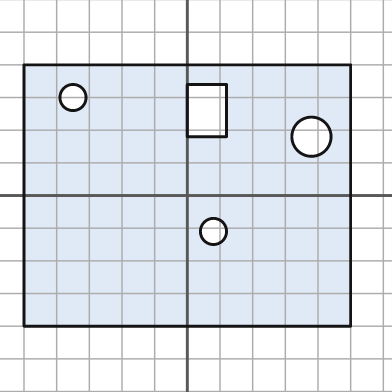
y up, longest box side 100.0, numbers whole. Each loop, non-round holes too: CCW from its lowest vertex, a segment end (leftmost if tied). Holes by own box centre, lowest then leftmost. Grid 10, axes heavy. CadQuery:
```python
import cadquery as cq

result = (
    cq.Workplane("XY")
    .moveTo(-50.0, -40.0)
    .lineTo(50.0, -40.0)
    .lineTo(50.0, 40.0)
    .lineTo(-50.0, 40.0)
    .close()
    .moveTo(8.0, -11.0)
    .circle(4.0)
    .moveTo(38.0, 18.0)
    .circle(6.0)
    .moveTo(0.0, 18.0)
    .lineTo(12.0, 18.0)
    .lineTo(12.0, 34.0)
    .lineTo(0.0, 34.0)
    .close()
    .moveTo(-35.0, 30.0)
    .circle(4.0)
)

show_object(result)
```